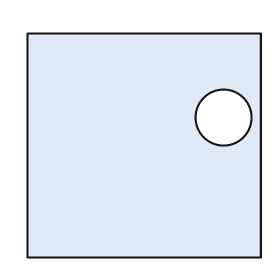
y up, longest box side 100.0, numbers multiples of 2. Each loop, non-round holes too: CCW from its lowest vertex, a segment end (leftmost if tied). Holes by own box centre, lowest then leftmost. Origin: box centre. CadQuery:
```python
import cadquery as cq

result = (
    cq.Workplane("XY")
    .moveTo(-50.0, -48.0)
    .lineTo(50.0, -48.0)
    .lineTo(50.0, 48.0)
    .lineTo(-50.0, 48.0)
    .close()
    .moveTo(34.0, 12.0)
    .circle(12.0)
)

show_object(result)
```